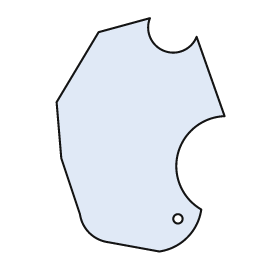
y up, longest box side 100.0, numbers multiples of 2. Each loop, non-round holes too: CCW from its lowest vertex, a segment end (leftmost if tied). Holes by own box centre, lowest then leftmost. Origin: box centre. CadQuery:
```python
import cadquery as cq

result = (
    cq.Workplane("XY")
    .moveTo(8.0, -50.0)
    .threePointArc((20.0, -44.0), (26.0, -32.0))
    .threePointArc((16.0, -8.0), (36.0, 8.0))
    .lineTo(24.0, 42.0)
    .threePointArc((10.0, 36.0), (4.0, 50.0))
    .lineTo(-18.0, 44.0)
    .lineTo(-36.0, 14.0)
    .lineTo(-34.0, -10.0)
    .lineTo(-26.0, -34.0)
    .threePointArc((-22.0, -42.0), (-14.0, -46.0))
    .close()
    .moveTo(16.0, -36.0)
    .circle(2.0)
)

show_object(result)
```